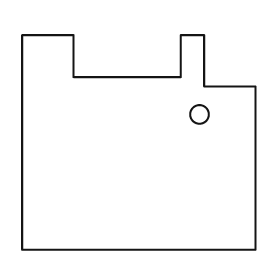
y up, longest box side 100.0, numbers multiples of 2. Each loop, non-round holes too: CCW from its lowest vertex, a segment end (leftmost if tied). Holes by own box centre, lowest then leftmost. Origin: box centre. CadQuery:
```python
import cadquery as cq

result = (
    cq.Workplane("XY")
    .moveTo(-50.0, -46.0)
    .lineTo(50.0, -46.0)
    .lineTo(50.0, 24.0)
    .lineTo(28.0, 24.0)
    .lineTo(28.0, 46.0)
    .lineTo(18.0, 46.0)
    .lineTo(18.0, 28.0)
    .lineTo(-28.0, 28.0)
    .lineTo(-28.0, 46.0)
    .lineTo(-50.0, 46.0)
    .close()
    .moveTo(26.0, 12.0)
    .circle(4.0)
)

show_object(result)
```